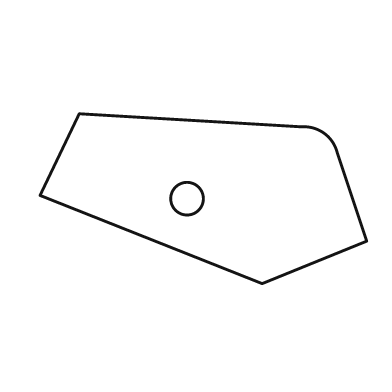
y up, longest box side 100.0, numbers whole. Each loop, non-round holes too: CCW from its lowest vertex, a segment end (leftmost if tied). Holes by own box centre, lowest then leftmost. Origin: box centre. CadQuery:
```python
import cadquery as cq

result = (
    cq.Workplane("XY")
    .moveTo(18.0, -26.0)
    .lineTo(50.0, -13.0)
    .lineTo(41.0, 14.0)
    .threePointArc((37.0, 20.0), (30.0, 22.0))
    .lineTo(-38.0, 26.0)
    .lineTo(-50.0, 1.0)
    .close()
    .moveTo(-5.0, 0.0)
    .circle(5.0)
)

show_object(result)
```